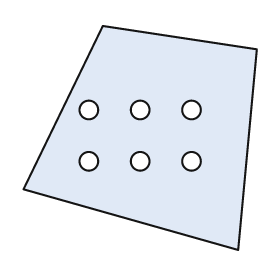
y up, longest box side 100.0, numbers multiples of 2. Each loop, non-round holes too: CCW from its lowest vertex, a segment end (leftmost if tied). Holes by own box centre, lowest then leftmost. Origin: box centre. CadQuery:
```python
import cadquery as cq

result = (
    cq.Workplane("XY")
    .moveTo(42.0, -48.0)
    .lineTo(50.0, 38.0)
    .lineTo(-16.0, 48.0)
    .lineTo(-50.0, -22.0)
    .close()
    .moveTo(-22.0, -10.0)
    .circle(4.0)
    .moveTo(0.0, -10.0)
    .circle(4.0)
    .moveTo(22.0, -10.0)
    .circle(4.0)
    .moveTo(-22.0, 12.0)
    .circle(4.0)
    .moveTo(0.0, 12.0)
    .circle(4.0)
    .moveTo(22.0, 12.0)
    .circle(4.0)
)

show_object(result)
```